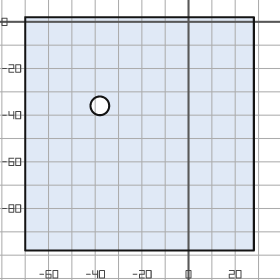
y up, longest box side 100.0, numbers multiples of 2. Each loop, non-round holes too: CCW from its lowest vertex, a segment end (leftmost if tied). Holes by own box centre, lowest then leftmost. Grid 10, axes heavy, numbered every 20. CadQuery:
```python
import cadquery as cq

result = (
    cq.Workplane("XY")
    .moveTo(-70.0, -98.0)
    .lineTo(28.0, -98.0)
    .lineTo(28.0, 2.0)
    .lineTo(-70.0, 2.0)
    .close()
    .moveTo(-38.0, -36.0)
    .circle(4.0)
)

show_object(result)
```